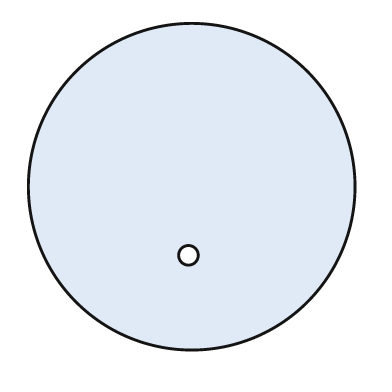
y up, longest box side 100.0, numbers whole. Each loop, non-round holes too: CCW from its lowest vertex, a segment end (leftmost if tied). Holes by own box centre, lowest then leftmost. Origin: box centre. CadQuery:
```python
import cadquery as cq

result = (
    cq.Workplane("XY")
    .moveTo(0.0, 0.0)
    .circle(50.0)
    .moveTo(-1.0, -21.0)
    .circle(3.0)
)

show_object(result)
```